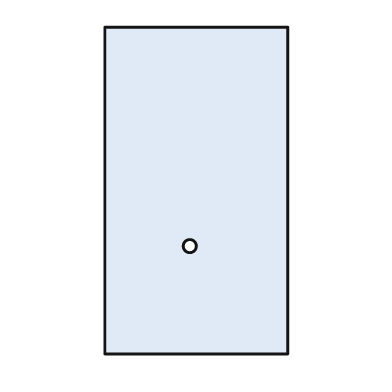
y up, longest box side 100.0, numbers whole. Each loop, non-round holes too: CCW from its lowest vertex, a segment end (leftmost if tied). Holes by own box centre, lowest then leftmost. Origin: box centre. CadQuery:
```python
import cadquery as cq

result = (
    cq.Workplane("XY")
    .moveTo(-28.0, -50.0)
    .lineTo(28.0, -50.0)
    .lineTo(28.0, 50.0)
    .lineTo(-28.0, 50.0)
    .close()
    .moveTo(-2.0, -17.0)
    .circle(2.0)
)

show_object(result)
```